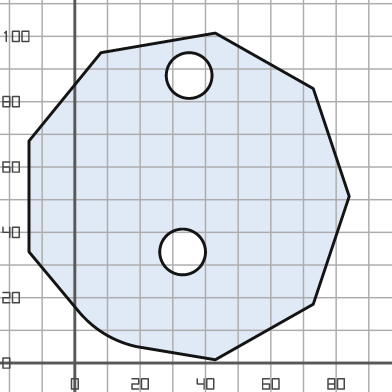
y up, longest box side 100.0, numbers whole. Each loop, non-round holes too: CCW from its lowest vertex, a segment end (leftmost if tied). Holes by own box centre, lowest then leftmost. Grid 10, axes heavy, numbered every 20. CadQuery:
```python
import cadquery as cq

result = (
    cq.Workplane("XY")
    .moveTo(43.0, 1.0)
    .lineTo(73.0, 18.0)
    .lineTo(84.0, 51.0)
    .lineTo(73.0, 84.0)
    .lineTo(43.0, 101.0)
    .lineTo(8.0, 95.0)
    .lineTo(-14.0, 68.0)
    .lineTo(-14.0, 34.0)
    .lineTo(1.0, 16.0)
    .threePointArc((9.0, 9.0), (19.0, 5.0))
    .close()
    .moveTo(33.0, 34.0)
    .circle(7.0)
    .moveTo(35.0, 88.0)
    .circle(7.0)
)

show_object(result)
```